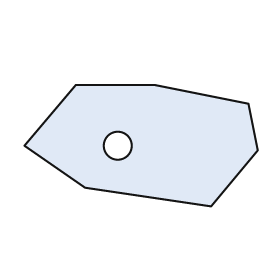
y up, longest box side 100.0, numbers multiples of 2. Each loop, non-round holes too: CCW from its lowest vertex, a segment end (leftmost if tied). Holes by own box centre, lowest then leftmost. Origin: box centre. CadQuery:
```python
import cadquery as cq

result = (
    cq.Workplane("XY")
    .moveTo(30.0, -26.0)
    .lineTo(50.0, -2.0)
    .lineTo(46.0, 18.0)
    .lineTo(6.0, 26.0)
    .lineTo(-28.0, 26.0)
    .lineTo(-50.0, 0.0)
    .lineTo(-24.0, -18.0)
    .close()
    .moveTo(-10.0, 0.0)
    .circle(6.0)
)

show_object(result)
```